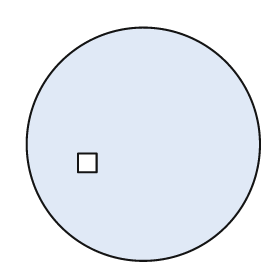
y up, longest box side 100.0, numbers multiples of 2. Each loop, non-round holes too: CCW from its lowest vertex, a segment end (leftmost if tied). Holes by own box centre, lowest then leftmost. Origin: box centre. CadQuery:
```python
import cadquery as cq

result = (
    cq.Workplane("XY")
    .moveTo(0.0, 0.0)
    .circle(50.0)
    .moveTo(-28.0, -12.0)
    .lineTo(-20.0, -12.0)
    .lineTo(-20.0, -4.0)
    .lineTo(-28.0, -4.0)
    .close()
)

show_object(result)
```